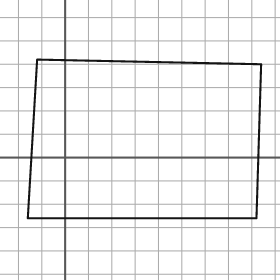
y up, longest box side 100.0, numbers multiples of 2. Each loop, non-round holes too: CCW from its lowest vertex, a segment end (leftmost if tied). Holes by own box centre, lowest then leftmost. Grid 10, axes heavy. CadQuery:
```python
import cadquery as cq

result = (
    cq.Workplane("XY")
    .moveTo(-16.0, -26.0)
    .lineTo(82.0, -26.0)
    .lineTo(84.0, 40.0)
    .lineTo(-12.0, 42.0)
    .close()
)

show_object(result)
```